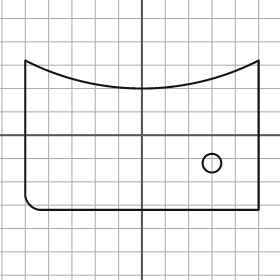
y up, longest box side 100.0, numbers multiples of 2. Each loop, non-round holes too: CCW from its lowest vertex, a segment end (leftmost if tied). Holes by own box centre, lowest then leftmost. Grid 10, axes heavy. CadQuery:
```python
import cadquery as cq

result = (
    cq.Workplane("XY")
    .moveTo(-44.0, -32.0)
    .lineTo(50.0, -32.0)
    .lineTo(50.0, 32.0)
    .threePointArc((0.0, 20.0), (-50.0, 32.0))
    .lineTo(-50.0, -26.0)
    .threePointArc((-48.0, -30.0), (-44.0, -32.0))
    .close()
    .moveTo(30.0, -12.0)
    .circle(4.0)
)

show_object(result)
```